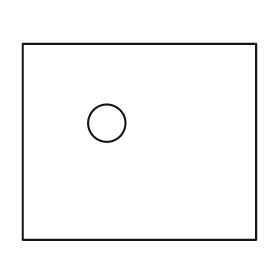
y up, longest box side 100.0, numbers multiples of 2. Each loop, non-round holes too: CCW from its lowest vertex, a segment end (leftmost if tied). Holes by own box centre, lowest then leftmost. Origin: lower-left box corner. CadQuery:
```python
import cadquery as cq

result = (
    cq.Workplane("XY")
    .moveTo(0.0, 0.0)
    .lineTo(100.0, 0.0)
    .lineTo(100.0, 84.0)
    .lineTo(0.0, 84.0)
    .close()
    .moveTo(36.0, 50.0)
    .circle(8.0)
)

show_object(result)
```